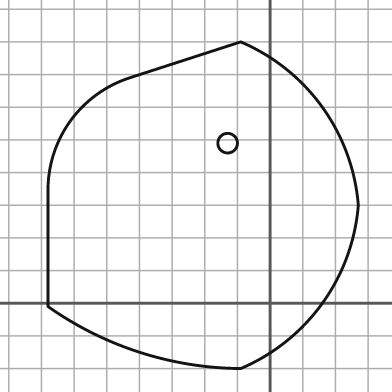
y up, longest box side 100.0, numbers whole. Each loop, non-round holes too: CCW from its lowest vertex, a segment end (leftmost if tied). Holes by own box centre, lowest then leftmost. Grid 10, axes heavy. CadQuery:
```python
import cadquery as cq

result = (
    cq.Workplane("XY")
    .moveTo(-9.0, -20.0)
    .threePointArc((16.0, 0.0), (27.0, 30.0))
    .threePointArc((16.0, 60.0), (-9.0, 80.0))
    .lineTo(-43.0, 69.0)
    .threePointArc((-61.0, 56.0), (-68.0, 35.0))
    .lineTo(-68.0, -1.0)
    .threePointArc((-40.0, -15.0), (-9.0, -20.0))
    .close()
    .moveTo(-13.0, 49.0)
    .circle(3.0)
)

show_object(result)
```